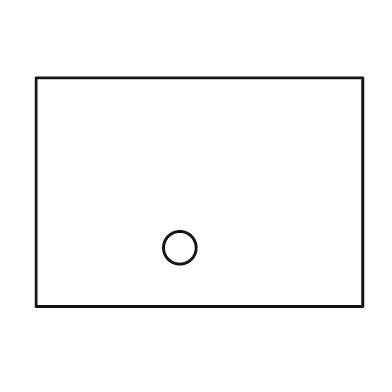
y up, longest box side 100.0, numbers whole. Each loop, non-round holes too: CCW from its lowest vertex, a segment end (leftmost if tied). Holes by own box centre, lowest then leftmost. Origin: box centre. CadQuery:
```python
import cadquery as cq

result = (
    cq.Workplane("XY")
    .moveTo(-50.0, -35.0)
    .lineTo(50.0, -35.0)
    .lineTo(50.0, 35.0)
    .lineTo(-50.0, 35.0)
    .close()
    .moveTo(-6.0, -17.0)
    .circle(5.0)
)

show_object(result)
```